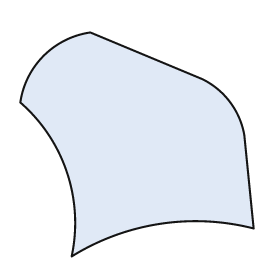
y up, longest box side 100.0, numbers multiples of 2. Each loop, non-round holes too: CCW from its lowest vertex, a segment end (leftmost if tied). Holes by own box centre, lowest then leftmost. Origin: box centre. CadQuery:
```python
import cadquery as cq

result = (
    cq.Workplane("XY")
    .moveTo(-28.0, -48.0)
    .threePointArc((10.0, -34.0), (50.0, -36.0))
    .lineTo(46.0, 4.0)
    .threePointArc((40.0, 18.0), (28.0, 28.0))
    .lineTo(-20.0, 48.0)
    .threePointArc((-40.0, 38.0), (-50.0, 18.0))
    .threePointArc((-30.0, -12.0), (-28.0, -48.0))
    .close()
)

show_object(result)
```